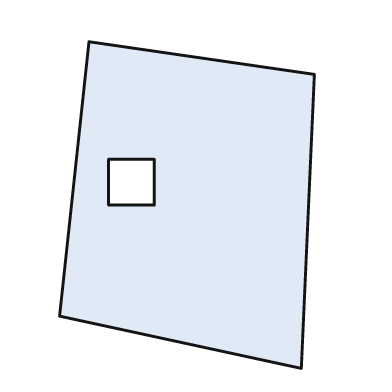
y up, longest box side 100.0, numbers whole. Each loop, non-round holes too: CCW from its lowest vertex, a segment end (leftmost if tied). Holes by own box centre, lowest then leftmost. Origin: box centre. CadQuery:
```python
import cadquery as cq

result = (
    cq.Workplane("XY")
    .moveTo(35.0, -50.0)
    .lineTo(39.0, 40.0)
    .lineTo(-30.0, 50.0)
    .lineTo(-39.0, -34.0)
    .close()
    .moveTo(-24.0, 0.0)
    .lineTo(-10.0, 0.0)
    .lineTo(-10.0, 14.0)
    .lineTo(-24.0, 14.0)
    .close()
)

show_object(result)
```